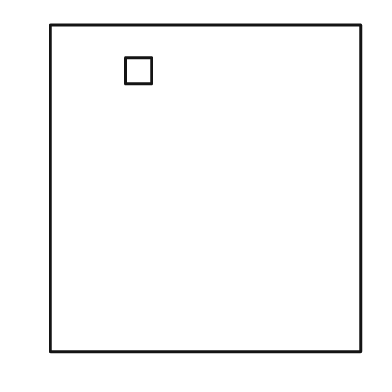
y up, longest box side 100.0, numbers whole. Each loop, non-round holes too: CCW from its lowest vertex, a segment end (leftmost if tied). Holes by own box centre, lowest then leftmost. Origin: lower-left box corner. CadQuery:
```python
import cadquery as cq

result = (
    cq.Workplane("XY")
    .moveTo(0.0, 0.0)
    .lineTo(95.0, 0.0)
    .lineTo(95.0, 100.0)
    .lineTo(0.0, 100.0)
    .close()
    .moveTo(23.0, 82.0)
    .lineTo(31.0, 82.0)
    .lineTo(31.0, 90.0)
    .lineTo(23.0, 90.0)
    .close()
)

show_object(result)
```